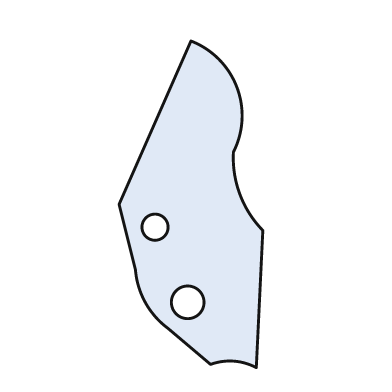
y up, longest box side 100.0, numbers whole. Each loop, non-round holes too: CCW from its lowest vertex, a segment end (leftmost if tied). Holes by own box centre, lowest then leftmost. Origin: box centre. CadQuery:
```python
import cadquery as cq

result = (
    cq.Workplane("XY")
    .moveTo(20.0, -50.0)
    .lineTo(22.0, -8.0)
    .threePointArc((15.0, 3.0), (13.0, 16.0))
    .threePointArc((14.0, 36.0), (0.0, 50.0))
    .lineTo(-22.0, 0.0)
    .lineTo(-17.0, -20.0)
    .threePointArc((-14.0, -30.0), (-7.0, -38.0))
    .lineTo(6.0, -49.0)
    .threePointArc((13.0, -48.0), (20.0, -50.0))
    .close()
    .moveTo(-1.0, -30.0)
    .circle(5.0)
    .moveTo(-11.0, -7.0)
    .circle(4.0)
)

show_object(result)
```